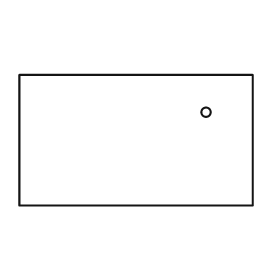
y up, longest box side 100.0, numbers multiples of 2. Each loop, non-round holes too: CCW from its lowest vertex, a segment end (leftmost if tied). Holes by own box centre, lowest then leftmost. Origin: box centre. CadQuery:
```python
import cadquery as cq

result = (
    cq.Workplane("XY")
    .moveTo(-50.0, -28.0)
    .lineTo(50.0, -28.0)
    .lineTo(50.0, 28.0)
    .lineTo(-50.0, 28.0)
    .close()
    .moveTo(30.0, 12.0)
    .circle(2.0)
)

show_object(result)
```